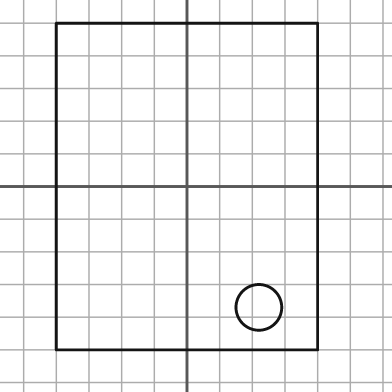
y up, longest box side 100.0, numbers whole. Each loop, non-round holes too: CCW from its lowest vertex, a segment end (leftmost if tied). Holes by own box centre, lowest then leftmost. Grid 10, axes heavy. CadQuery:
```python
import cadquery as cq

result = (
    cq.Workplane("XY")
    .moveTo(-40.0, -50.0)
    .lineTo(40.0, -50.0)
    .lineTo(40.0, 50.0)
    .lineTo(-40.0, 50.0)
    .close()
    .moveTo(22.0, -37.0)
    .circle(7.0)
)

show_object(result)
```